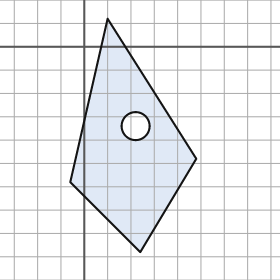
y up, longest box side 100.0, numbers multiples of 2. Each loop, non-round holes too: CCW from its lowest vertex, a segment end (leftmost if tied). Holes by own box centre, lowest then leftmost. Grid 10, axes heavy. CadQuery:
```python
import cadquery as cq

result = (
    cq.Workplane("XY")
    .moveTo(24.0, -88.0)
    .lineTo(48.0, -48.0)
    .lineTo(10.0, 12.0)
    .lineTo(-6.0, -58.0)
    .close()
    .moveTo(22.0, -34.0)
    .circle(6.0)
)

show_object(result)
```